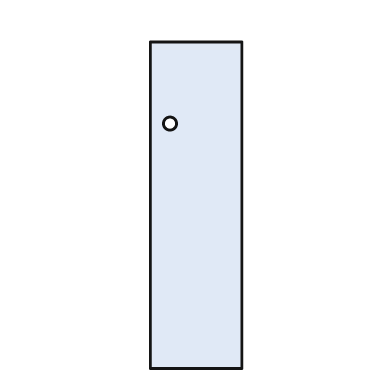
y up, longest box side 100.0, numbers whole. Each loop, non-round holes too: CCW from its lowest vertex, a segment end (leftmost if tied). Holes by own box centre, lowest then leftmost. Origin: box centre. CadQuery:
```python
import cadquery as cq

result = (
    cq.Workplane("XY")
    .moveTo(-14.0, -50.0)
    .lineTo(14.0, -50.0)
    .lineTo(14.0, 50.0)
    .lineTo(-14.0, 50.0)
    .close()
    .moveTo(-8.0, 25.0)
    .circle(2.0)
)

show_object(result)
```